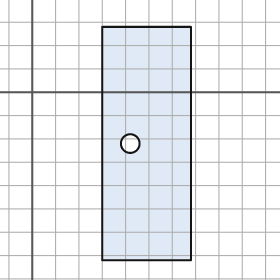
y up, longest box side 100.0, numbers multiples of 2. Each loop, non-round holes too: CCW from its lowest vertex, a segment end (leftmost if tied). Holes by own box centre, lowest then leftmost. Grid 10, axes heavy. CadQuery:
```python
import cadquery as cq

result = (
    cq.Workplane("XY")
    .moveTo(30.0, -72.0)
    .lineTo(68.0, -72.0)
    .lineTo(68.0, 28.0)
    .lineTo(30.0, 28.0)
    .close()
    .moveTo(42.0, -22.0)
    .circle(4.0)
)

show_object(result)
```